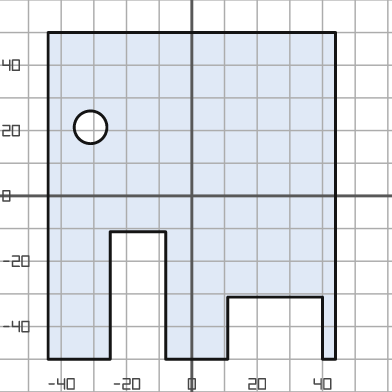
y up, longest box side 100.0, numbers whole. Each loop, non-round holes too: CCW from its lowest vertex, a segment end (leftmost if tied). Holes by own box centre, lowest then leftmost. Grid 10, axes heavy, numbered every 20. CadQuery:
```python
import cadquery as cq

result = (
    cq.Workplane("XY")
    .moveTo(-44.0, -50.0)
    .lineTo(-25.0, -50.0)
    .lineTo(-25.0, -11.0)
    .lineTo(-8.0, -11.0)
    .lineTo(-8.0, -50.0)
    .lineTo(11.0, -50.0)
    .lineTo(11.0, -31.0)
    .lineTo(40.0, -31.0)
    .lineTo(40.0, -50.0)
    .lineTo(44.0, -50.0)
    .lineTo(44.0, 50.0)
    .lineTo(-44.0, 50.0)
    .close()
    .moveTo(-31.0, 21.0)
    .circle(5.0)
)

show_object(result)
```